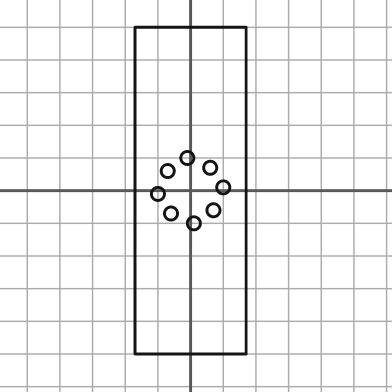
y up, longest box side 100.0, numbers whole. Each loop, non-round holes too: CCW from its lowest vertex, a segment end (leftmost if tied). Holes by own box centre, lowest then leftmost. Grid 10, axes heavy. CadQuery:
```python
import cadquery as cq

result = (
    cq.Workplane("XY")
    .moveTo(-17.0, -50.0)
    .lineTo(17.0, -50.0)
    .lineTo(17.0, 50.0)
    .lineTo(-17.0, 50.0)
    .close()
    .moveTo(1.0, -10.0)
    .circle(2.0)
    .moveTo(-6.0, -7.0)
    .circle(2.0)
    .moveTo(7.0, -6.0)
    .circle(2.0)
    .moveTo(-10.0, -1.0)
    .circle(2.0)
    .moveTo(10.0, 1.0)
    .circle(2.0)
    .moveTo(-7.0, 6.0)
    .circle(2.0)
    .moveTo(6.0, 7.0)
    .circle(2.0)
    .moveTo(-1.0, 10.0)
    .circle(2.0)
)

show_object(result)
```